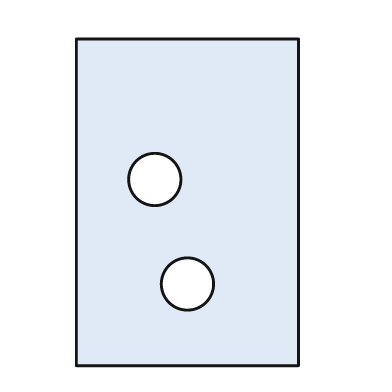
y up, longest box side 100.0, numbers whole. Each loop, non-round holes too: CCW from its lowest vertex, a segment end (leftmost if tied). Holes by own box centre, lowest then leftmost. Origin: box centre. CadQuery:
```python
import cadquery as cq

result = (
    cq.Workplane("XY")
    .moveTo(-34.0, -50.0)
    .lineTo(34.0, -50.0)
    .lineTo(34.0, 50.0)
    .lineTo(-34.0, 50.0)
    .close()
    .moveTo(0.0, -25.0)
    .circle(8.0)
    .moveTo(-10.0, 7.0)
    .circle(8.0)
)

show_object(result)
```